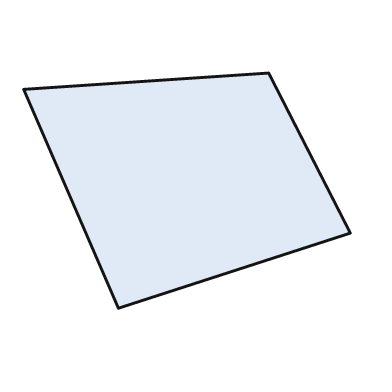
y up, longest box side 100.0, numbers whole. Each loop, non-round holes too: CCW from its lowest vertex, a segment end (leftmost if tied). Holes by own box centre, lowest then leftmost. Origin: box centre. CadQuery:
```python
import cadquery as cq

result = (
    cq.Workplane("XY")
    .moveTo(-21.0, -36.0)
    .lineTo(50.0, -13.0)
    .lineTo(25.0, 36.0)
    .lineTo(-50.0, 31.0)
    .close()
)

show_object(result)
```